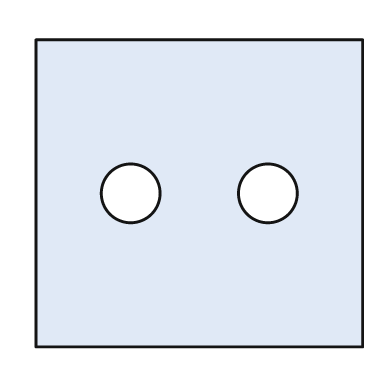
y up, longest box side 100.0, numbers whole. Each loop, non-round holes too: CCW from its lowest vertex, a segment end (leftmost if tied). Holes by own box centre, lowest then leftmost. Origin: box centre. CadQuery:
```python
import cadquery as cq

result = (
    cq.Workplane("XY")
    .moveTo(-50.0, -47.0)
    .lineTo(50.0, -47.0)
    .lineTo(50.0, 47.0)
    .lineTo(-50.0, 47.0)
    .close()
    .moveTo(-21.0, 0.0)
    .circle(9.0)
    .moveTo(21.0, 0.0)
    .circle(9.0)
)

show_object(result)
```